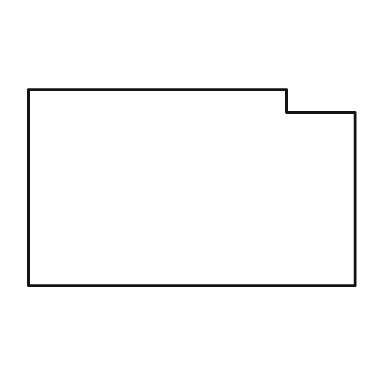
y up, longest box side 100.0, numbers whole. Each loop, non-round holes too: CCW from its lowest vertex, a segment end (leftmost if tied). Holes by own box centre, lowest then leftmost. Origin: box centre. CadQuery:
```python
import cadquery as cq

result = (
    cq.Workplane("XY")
    .moveTo(-50.0, -30.0)
    .lineTo(50.0, -30.0)
    .lineTo(50.0, 23.0)
    .lineTo(29.0, 23.0)
    .lineTo(29.0, 30.0)
    .lineTo(-50.0, 30.0)
    .close()
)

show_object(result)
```